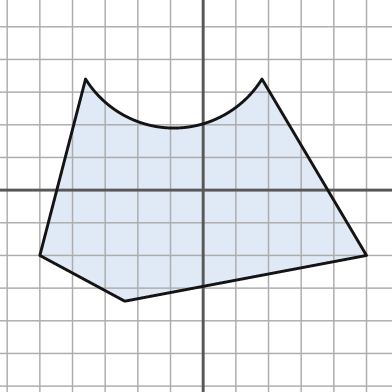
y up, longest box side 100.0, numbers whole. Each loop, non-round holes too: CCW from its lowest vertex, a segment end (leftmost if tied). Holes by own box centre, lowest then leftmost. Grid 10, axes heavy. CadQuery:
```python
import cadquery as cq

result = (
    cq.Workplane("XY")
    .moveTo(-24.0, -34.0)
    .lineTo(50.0, -20.0)
    .lineTo(18.0, 34.0)
    .threePointArc((-9.0, 19.0), (-36.0, 34.0))
    .lineTo(-50.0, -20.0)
    .close()
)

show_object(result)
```